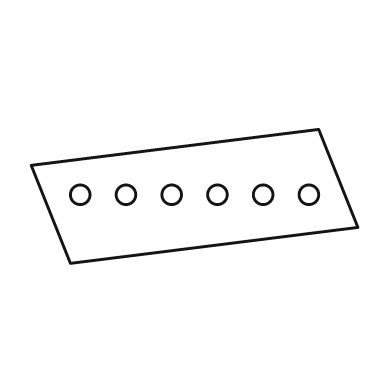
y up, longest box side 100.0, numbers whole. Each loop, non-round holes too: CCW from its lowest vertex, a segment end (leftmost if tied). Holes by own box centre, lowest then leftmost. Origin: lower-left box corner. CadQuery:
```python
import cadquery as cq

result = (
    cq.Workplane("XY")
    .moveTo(12.0, 0.0)
    .lineTo(100.0, 11.0)
    .lineTo(88.0, 41.0)
    .lineTo(0.0, 30.0)
    .close()
    .moveTo(15.0, 21.0)
    .circle(3.0)
    .moveTo(29.0, 21.0)
    .circle(3.0)
    .moveTo(43.0, 21.0)
    .circle(3.0)
    .moveTo(57.0, 21.0)
    .circle(3.0)
    .moveTo(71.0, 21.0)
    .circle(3.0)
    .moveTo(85.0, 21.0)
    .circle(3.0)
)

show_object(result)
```